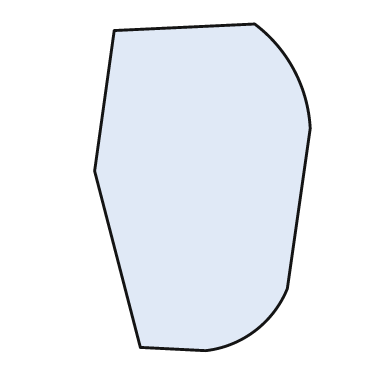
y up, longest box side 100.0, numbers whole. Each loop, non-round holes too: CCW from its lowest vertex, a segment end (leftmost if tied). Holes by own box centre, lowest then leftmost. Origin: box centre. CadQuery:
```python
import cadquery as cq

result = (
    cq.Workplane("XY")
    .moveTo(1.0, -50.0)
    .threePointArc((16.0, -44.0), (26.0, -31.0))
    .lineTo(33.0, 18.0)
    .threePointArc((28.0, 36.0), (16.0, 50.0))
    .lineTo(-27.0, 48.0)
    .lineTo(-33.0, 5.0)
    .lineTo(-19.0, -49.0)
    .close()
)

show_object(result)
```